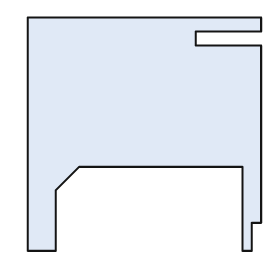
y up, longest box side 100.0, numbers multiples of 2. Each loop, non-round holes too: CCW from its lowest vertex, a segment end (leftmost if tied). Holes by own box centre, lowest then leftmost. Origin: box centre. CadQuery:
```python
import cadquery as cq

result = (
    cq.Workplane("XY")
    .moveTo(-50.0, -50.0)
    .lineTo(-38.0, -50.0)
    .lineTo(-38.0, -24.0)
    .lineTo(-28.0, -14.0)
    .lineTo(42.0, -14.0)
    .lineTo(42.0, -50.0)
    .lineTo(46.0, -50.0)
    .lineTo(46.0, -38.0)
    .lineTo(50.0, -38.0)
    .lineTo(50.0, 38.0)
    .lineTo(22.0, 38.0)
    .lineTo(22.0, 44.0)
    .lineTo(50.0, 44.0)
    .lineTo(50.0, 50.0)
    .lineTo(-50.0, 50.0)
    .close()
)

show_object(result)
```